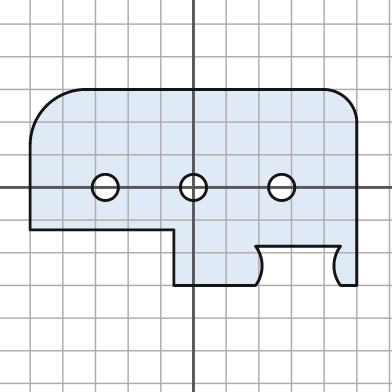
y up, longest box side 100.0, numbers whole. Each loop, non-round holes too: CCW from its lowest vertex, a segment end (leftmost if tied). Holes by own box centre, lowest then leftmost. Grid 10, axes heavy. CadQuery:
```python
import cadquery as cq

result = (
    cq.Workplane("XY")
    .moveTo(-6.0, -30.0)
    .lineTo(19.0, -30.0)
    .threePointArc((21.0, -24.0), (19.0, -18.0))
    .lineTo(45.0, -18.0)
    .threePointArc((43.0, -24.0), (45.0, -30.0))
    .lineTo(50.0, -30.0)
    .lineTo(50.0, 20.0)
    .threePointArc((47.0, 27.0), (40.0, 30.0))
    .lineTo(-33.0, 30.0)
    .threePointArc((-45.0, 25.0), (-50.0, 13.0))
    .lineTo(-50.0, -13.0)
    .lineTo(-6.0, -13.0)
    .close()
    .moveTo(-27.0, 0.0)
    .circle(4.0)
    .moveTo(0.0, 0.0)
    .circle(4.0)
    .moveTo(27.0, 0.0)
    .circle(4.0)
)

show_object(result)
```